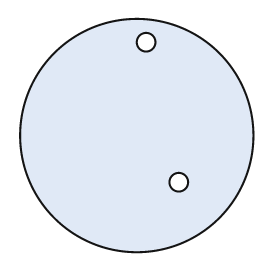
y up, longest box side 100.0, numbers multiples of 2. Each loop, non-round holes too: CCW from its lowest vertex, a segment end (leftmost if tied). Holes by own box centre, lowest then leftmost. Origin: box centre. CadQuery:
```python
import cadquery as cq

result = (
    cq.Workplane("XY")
    .moveTo(0.0, 0.0)
    .circle(50.0)
    .moveTo(18.0, -20.0)
    .circle(4.0)
    .moveTo(4.0, 40.0)
    .circle(4.0)
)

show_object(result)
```